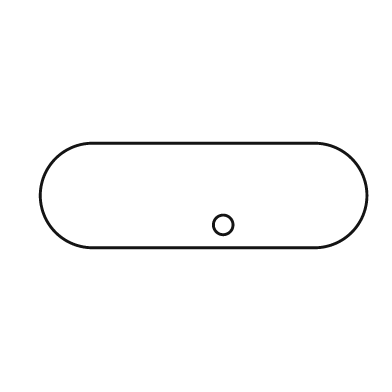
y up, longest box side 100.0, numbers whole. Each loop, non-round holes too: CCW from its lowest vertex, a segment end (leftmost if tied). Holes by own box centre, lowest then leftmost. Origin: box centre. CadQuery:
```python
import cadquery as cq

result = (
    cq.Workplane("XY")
    .moveTo(-34.0, -16.0)
    .lineTo(34.0, -16.0)
    .threePointArc((50.0, 0.0), (34.0, 16.0))
    .lineTo(-34.0, 16.0)
    .threePointArc((-50.0, 0.0), (-34.0, -16.0))
    .close()
    .moveTo(6.0, -9.0)
    .circle(3.0)
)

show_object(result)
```